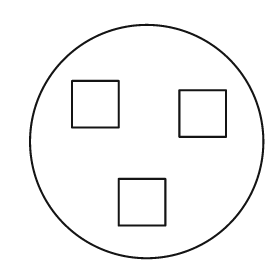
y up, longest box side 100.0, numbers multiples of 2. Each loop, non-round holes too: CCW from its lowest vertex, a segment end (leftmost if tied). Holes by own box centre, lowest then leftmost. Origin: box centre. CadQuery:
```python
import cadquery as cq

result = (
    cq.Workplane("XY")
    .moveTo(0.0, 0.0)
    .circle(50.0)
    .moveTo(-12.0, -36.0)
    .lineTo(8.0, -36.0)
    .lineTo(8.0, -16.0)
    .lineTo(-12.0, -16.0)
    .close()
    .moveTo(14.0, 2.0)
    .lineTo(34.0, 2.0)
    .lineTo(34.0, 22.0)
    .lineTo(14.0, 22.0)
    .close()
    .moveTo(-32.0, 6.0)
    .lineTo(-12.0, 6.0)
    .lineTo(-12.0, 26.0)
    .lineTo(-32.0, 26.0)
    .close()
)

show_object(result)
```